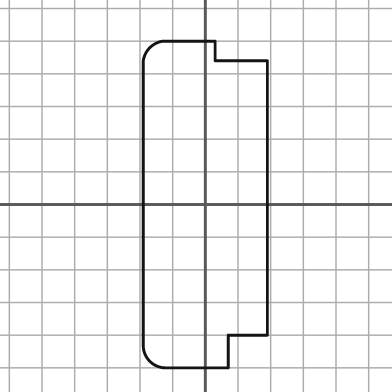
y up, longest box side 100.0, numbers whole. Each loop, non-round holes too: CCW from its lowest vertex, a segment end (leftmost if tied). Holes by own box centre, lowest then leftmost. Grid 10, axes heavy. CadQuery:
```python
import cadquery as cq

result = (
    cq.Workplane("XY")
    .moveTo(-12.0, -50.0)
    .lineTo(7.0, -50.0)
    .lineTo(7.0, -40.0)
    .lineTo(19.0, -40.0)
    .lineTo(19.0, 44.0)
    .lineTo(3.0, 44.0)
    .lineTo(3.0, 50.0)
    .lineTo(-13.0, 50.0)
    .threePointArc((-17.0, 48.0), (-19.0, 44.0))
    .lineTo(-19.0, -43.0)
    .threePointArc((-17.0, -48.0), (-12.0, -50.0))
    .close()
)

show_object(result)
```